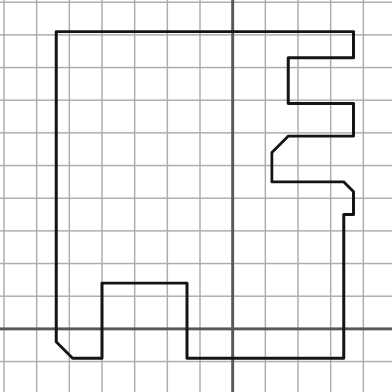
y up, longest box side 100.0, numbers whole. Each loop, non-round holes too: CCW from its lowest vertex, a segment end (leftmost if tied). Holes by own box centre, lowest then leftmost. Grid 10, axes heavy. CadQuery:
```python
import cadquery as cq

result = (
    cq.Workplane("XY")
    .moveTo(-49.0, -9.0)
    .lineTo(-40.0, -9.0)
    .lineTo(-40.0, 14.0)
    .lineTo(-14.0, 14.0)
    .lineTo(-14.0, -9.0)
    .lineTo(34.0, -9.0)
    .lineTo(34.0, 35.0)
    .lineTo(37.0, 35.0)
    .lineTo(37.0, 42.0)
    .lineTo(34.0, 45.0)
    .lineTo(12.0, 45.0)
    .lineTo(12.0, 54.0)
    .lineTo(17.0, 59.0)
    .lineTo(37.0, 59.0)
    .lineTo(37.0, 69.0)
    .lineTo(17.0, 69.0)
    .lineTo(17.0, 83.0)
    .lineTo(37.0, 83.0)
    .lineTo(37.0, 91.0)
    .lineTo(-54.0, 91.0)
    .lineTo(-54.0, -4.0)
    .close()
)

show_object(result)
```